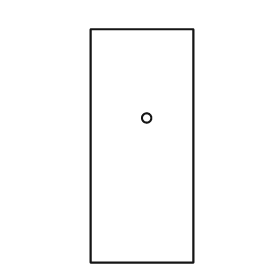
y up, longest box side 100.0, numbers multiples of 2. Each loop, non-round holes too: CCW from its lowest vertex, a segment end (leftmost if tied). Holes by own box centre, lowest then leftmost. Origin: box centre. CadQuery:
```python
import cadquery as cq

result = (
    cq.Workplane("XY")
    .moveTo(-22.0, -50.0)
    .lineTo(22.0, -50.0)
    .lineTo(22.0, 50.0)
    .lineTo(-22.0, 50.0)
    .close()
    .moveTo(2.0, 12.0)
    .circle(2.0)
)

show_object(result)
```